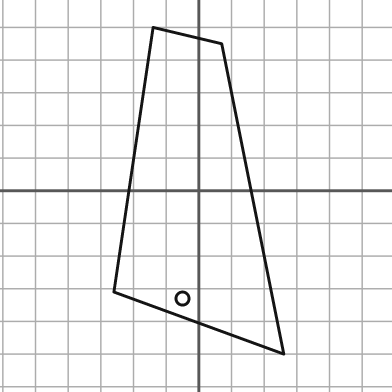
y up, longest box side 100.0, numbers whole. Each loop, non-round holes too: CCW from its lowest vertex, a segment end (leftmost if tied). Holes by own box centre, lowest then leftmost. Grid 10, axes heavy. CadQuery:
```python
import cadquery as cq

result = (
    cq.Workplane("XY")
    .moveTo(26.0, -50.0)
    .lineTo(7.0, 45.0)
    .lineTo(-14.0, 50.0)
    .lineTo(-26.0, -31.0)
    .close()
    .moveTo(-5.0, -33.0)
    .circle(2.0)
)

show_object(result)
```